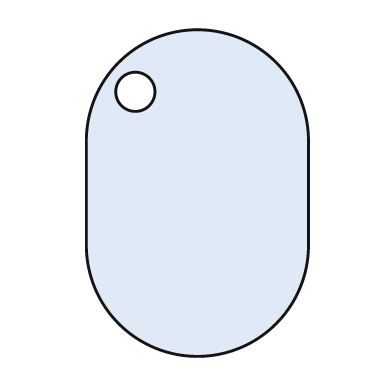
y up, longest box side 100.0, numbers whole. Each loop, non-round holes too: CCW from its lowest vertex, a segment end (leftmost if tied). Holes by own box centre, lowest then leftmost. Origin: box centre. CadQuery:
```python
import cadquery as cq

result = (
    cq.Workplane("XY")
    .moveTo(-34.0, -16.0)
    .threePointArc((0.0, -50.0), (34.0, -16.0))
    .lineTo(34.0, 16.0)
    .threePointArc((0.0, 50.0), (-34.0, 16.0))
    .close()
    .moveTo(-19.0, 31.0)
    .circle(6.0)
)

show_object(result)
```